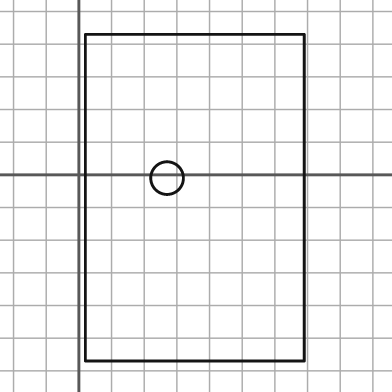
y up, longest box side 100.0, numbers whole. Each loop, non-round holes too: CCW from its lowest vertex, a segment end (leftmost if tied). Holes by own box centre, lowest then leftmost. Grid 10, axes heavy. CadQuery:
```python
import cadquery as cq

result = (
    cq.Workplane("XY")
    .moveTo(2.0, -57.0)
    .lineTo(69.0, -57.0)
    .lineTo(69.0, 43.0)
    .lineTo(2.0, 43.0)
    .close()
    .moveTo(27.0, -1.0)
    .circle(5.0)
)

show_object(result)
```